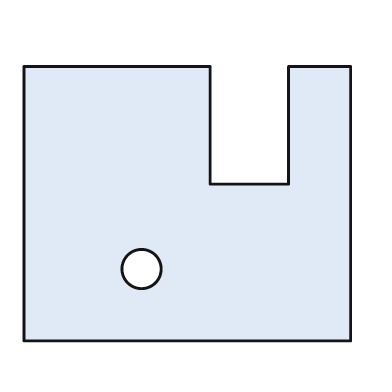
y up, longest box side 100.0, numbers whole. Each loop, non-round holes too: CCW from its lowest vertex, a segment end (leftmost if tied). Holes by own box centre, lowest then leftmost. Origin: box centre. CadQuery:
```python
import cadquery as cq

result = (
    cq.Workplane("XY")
    .moveTo(-50.0, -42.0)
    .lineTo(50.0, -42.0)
    .lineTo(50.0, 42.0)
    .lineTo(31.0, 42.0)
    .lineTo(31.0, 6.0)
    .lineTo(7.0, 6.0)
    .lineTo(7.0, 42.0)
    .lineTo(-50.0, 42.0)
    .close()
    .moveTo(-14.0, -20.0)
    .circle(6.0)
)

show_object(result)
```